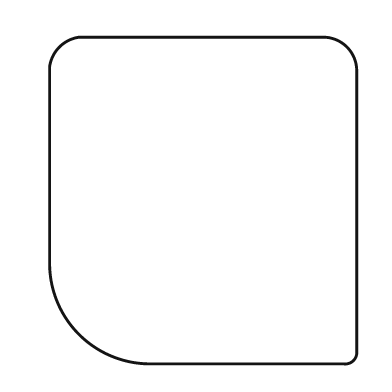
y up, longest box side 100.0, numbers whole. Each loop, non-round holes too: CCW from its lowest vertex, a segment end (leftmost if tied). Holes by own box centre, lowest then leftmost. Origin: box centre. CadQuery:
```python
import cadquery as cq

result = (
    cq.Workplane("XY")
    .moveTo(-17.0, -50.0)
    .lineTo(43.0, -50.0)
    .threePointArc((46.0, -49.0), (47.0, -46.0))
    .lineTo(47.0, 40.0)
    .threePointArc((44.0, 47.0), (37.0, 50.0))
    .lineTo(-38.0, 50.0)
    .threePointArc((-44.0, 47.0), (-47.0, 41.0))
    .lineTo(-47.0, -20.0)
    .threePointArc((-38.0, -41.0), (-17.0, -50.0))
    .close()
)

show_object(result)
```